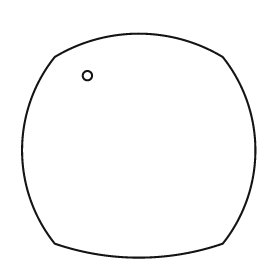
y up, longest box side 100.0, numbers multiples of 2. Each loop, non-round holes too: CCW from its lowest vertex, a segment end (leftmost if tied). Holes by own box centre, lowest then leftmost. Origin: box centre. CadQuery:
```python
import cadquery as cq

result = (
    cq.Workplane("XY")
    .moveTo(-36.0, -42.0)
    .threePointArc((0.0, -48.0), (36.0, -42.0))
    .threePointArc((50.0, -2.0), (36.0, 38.0))
    .threePointArc((0.0, 48.0), (-36.0, 38.0))
    .threePointArc((-50.0, -2.0), (-36.0, -42.0))
    .close()
    .moveTo(-22.0, 30.0)
    .circle(2.0)
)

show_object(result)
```